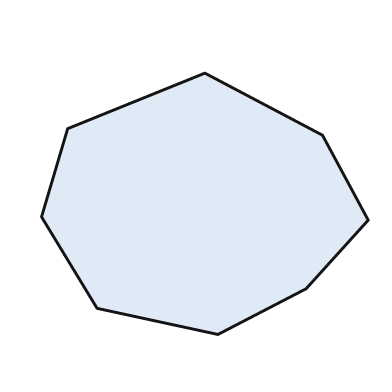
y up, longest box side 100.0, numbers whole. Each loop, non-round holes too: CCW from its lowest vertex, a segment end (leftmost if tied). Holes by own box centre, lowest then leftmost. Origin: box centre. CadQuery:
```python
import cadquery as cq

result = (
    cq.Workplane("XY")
    .moveTo(4.0, -40.0)
    .lineTo(31.0, -26.0)
    .lineTo(50.0, -5.0)
    .lineTo(36.0, 21.0)
    .lineTo(0.0, 40.0)
    .lineTo(-42.0, 23.0)
    .lineTo(-50.0, -4.0)
    .lineTo(-33.0, -32.0)
    .close()
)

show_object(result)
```